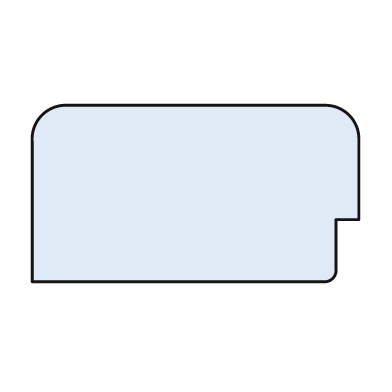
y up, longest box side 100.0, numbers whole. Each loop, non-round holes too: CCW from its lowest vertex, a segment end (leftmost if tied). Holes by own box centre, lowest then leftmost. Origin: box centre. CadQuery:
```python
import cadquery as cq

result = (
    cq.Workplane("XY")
    .moveTo(-50.0, -27.0)
    .lineTo(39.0, -27.0)
    .threePointArc((42.0, -26.0), (43.0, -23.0))
    .lineTo(43.0, -8.0)
    .lineTo(50.0, -8.0)
    .lineTo(50.0, 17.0)
    .threePointArc((47.0, 24.0), (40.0, 27.0))
    .lineTo(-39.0, 27.0)
    .threePointArc((-47.0, 24.0), (-50.0, 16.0))
    .close()
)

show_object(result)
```